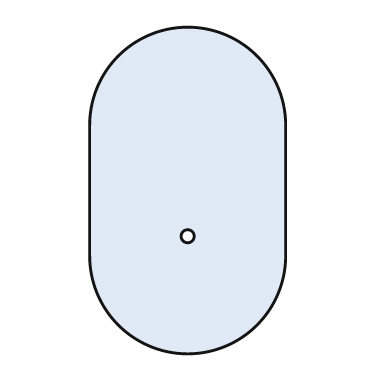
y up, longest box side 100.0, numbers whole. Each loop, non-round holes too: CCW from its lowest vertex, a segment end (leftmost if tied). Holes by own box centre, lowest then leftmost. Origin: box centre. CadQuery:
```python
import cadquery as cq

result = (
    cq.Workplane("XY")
    .moveTo(-30.0, -20.0)
    .threePointArc((0.0, -50.0), (30.0, -20.0))
    .lineTo(30.0, 20.0)
    .threePointArc((0.0, 50.0), (-30.0, 20.0))
    .close()
    .moveTo(0.0, -14.0)
    .circle(2.0)
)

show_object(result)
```